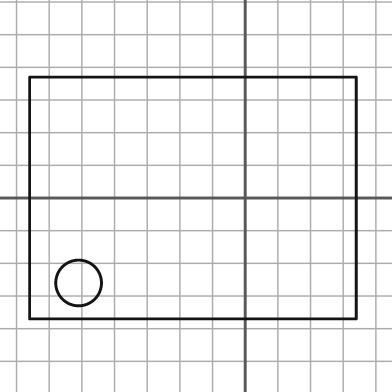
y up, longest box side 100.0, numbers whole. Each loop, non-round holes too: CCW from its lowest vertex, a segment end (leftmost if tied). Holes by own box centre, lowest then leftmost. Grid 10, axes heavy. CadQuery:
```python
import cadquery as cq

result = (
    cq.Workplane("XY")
    .moveTo(-66.0, -37.0)
    .lineTo(34.0, -37.0)
    .lineTo(34.0, 37.0)
    .lineTo(-66.0, 37.0)
    .close()
    .moveTo(-51.0, -26.0)
    .circle(7.0)
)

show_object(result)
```